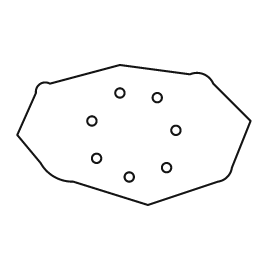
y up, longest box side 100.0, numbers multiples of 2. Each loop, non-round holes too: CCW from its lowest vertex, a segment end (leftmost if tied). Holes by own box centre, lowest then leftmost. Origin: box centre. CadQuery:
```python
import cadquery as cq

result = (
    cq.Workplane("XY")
    .moveTo(6.0, -30.0)
    .lineTo(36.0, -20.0)
    .threePointArc((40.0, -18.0), (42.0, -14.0))
    .lineTo(50.0, 6.0)
    .lineTo(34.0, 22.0)
    .threePointArc((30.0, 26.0), (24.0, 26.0))
    .lineTo(-6.0, 30.0)
    .lineTo(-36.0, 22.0)
    .threePointArc((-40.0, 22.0), (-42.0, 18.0))
    .lineTo(-50.0, 0.0)
    .lineTo(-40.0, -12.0)
    .threePointArc((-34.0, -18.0), (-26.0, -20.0))
    .close()
    .moveTo(-2.0, -18.0)
    .circle(2.0)
    .moveTo(14.0, -14.0)
    .circle(2.0)
    .moveTo(-16.0, -10.0)
    .circle(2.0)
    .moveTo(18.0, 2.0)
    .circle(2.0)
    .moveTo(-18.0, 6.0)
    .circle(2.0)
    .moveTo(10.0, 16.0)
    .circle(2.0)
    .moveTo(-6.0, 18.0)
    .circle(2.0)
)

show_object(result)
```